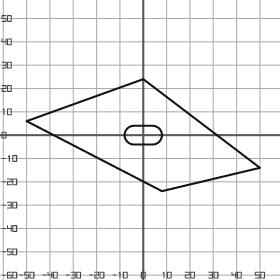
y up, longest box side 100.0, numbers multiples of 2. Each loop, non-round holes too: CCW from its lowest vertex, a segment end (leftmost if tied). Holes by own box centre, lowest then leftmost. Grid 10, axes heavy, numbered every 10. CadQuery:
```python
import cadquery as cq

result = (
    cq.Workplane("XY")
    .moveTo(8.0, -24.0)
    .lineTo(50.0, -14.0)
    .lineTo(0.0, 24.0)
    .lineTo(-50.0, 6.0)
    .close()
    .moveTo(-4.0, -4.0)
    .lineTo(4.0, -4.0)
    .threePointArc((8.0, 0.0), (4.0, 4.0))
    .lineTo(-4.0, 4.0)
    .threePointArc((-8.0, 0.0), (-4.0, -4.0))
    .close()
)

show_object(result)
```